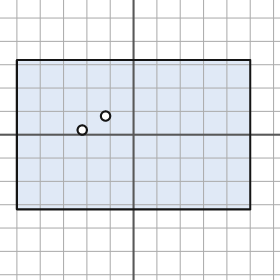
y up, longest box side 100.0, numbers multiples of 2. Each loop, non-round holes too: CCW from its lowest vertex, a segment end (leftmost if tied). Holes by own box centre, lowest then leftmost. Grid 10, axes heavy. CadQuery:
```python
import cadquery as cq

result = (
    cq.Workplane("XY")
    .moveTo(-50.0, -32.0)
    .lineTo(50.0, -32.0)
    .lineTo(50.0, 32.0)
    .lineTo(-50.0, 32.0)
    .close()
    .moveTo(-22.0, 2.0)
    .circle(2.0)
    .moveTo(-12.0, 8.0)
    .circle(2.0)
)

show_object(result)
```